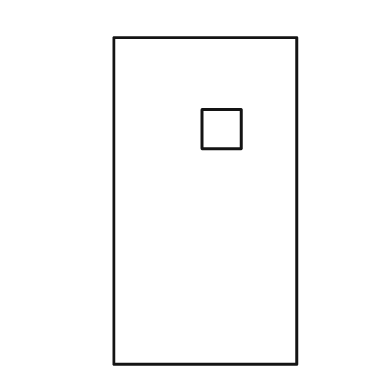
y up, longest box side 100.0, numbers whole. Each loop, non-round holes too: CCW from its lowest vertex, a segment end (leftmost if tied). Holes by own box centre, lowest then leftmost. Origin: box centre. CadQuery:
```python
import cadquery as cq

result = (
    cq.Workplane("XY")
    .moveTo(-28.0, -50.0)
    .lineTo(28.0, -50.0)
    .lineTo(28.0, 50.0)
    .lineTo(-28.0, 50.0)
    .close()
    .moveTo(-1.0, 16.0)
    .lineTo(11.0, 16.0)
    .lineTo(11.0, 28.0)
    .lineTo(-1.0, 28.0)
    .close()
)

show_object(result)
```